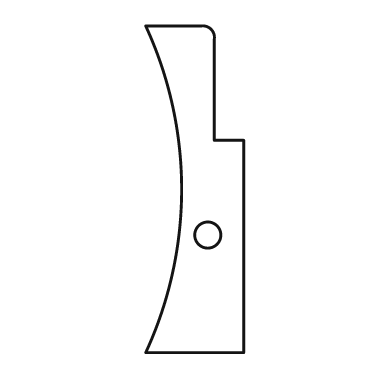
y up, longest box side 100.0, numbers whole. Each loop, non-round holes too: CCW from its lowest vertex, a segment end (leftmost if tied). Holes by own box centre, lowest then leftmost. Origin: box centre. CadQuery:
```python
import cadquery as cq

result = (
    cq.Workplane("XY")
    .moveTo(-15.0, -50.0)
    .lineTo(15.0, -50.0)
    .lineTo(15.0, 15.0)
    .lineTo(6.0, 15.0)
    .lineTo(6.0, 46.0)
    .threePointArc((5.0, 49.0), (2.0, 50.0))
    .lineTo(-15.0, 50.0)
    .threePointArc((-4.0, 0.0), (-15.0, -50.0))
    .close()
    .moveTo(4.0, -14.0)
    .circle(4.0)
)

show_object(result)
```